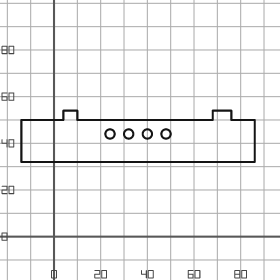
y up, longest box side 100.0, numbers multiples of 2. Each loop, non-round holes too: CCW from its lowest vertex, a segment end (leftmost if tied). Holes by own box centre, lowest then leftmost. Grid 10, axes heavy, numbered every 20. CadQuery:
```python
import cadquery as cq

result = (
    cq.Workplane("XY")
    .moveTo(-14.0, 32.0)
    .lineTo(86.0, 32.0)
    .lineTo(86.0, 50.0)
    .lineTo(76.0, 50.0)
    .lineTo(76.0, 54.0)
    .lineTo(68.0, 54.0)
    .lineTo(68.0, 50.0)
    .lineTo(10.0, 50.0)
    .lineTo(10.0, 54.0)
    .lineTo(4.0, 54.0)
    .lineTo(4.0, 50.0)
    .lineTo(-14.0, 50.0)
    .close()
    .moveTo(24.0, 44.0)
    .circle(2.0)
    .moveTo(32.0, 44.0)
    .circle(2.0)
    .moveTo(40.0, 44.0)
    .circle(2.0)
    .moveTo(48.0, 44.0)
    .circle(2.0)
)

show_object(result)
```